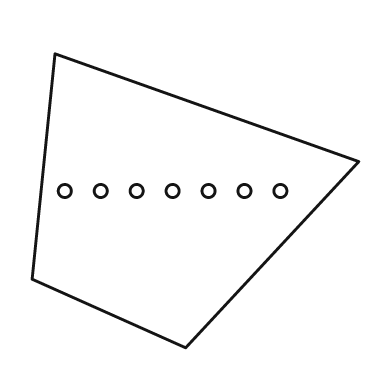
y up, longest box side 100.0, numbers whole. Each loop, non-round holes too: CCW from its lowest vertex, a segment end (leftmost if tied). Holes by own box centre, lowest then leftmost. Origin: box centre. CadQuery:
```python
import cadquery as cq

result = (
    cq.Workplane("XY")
    .moveTo(-3.0, -45.0)
    .lineTo(50.0, 12.0)
    .lineTo(-43.0, 45.0)
    .lineTo(-50.0, -24.0)
    .close()
    .moveTo(-40.0, 3.0)
    .circle(2.0)
    .moveTo(-29.0, 3.0)
    .circle(2.0)
    .moveTo(-18.0, 3.0)
    .circle(2.0)
    .moveTo(-7.0, 3.0)
    .circle(2.0)
    .moveTo(4.0, 3.0)
    .circle(2.0)
    .moveTo(15.0, 3.0)
    .circle(2.0)
    .moveTo(26.0, 3.0)
    .circle(2.0)
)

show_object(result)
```